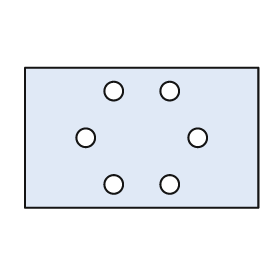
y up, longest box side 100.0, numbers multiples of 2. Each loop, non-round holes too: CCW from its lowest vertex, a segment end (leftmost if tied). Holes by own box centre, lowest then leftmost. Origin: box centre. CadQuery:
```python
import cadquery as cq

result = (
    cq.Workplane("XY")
    .moveTo(-50.0, -30.0)
    .lineTo(50.0, -30.0)
    .lineTo(50.0, 30.0)
    .lineTo(-50.0, 30.0)
    .close()
    .moveTo(-12.0, -20.0)
    .circle(4.0)
    .moveTo(12.0, -20.0)
    .circle(4.0)
    .moveTo(-24.0, 0.0)
    .circle(4.0)
    .moveTo(24.0, 0.0)
    .circle(4.0)
    .moveTo(-12.0, 20.0)
    .circle(4.0)
    .moveTo(12.0, 20.0)
    .circle(4.0)
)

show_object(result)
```